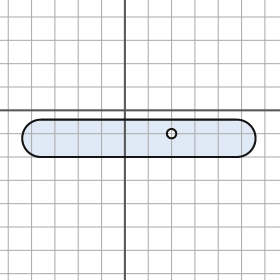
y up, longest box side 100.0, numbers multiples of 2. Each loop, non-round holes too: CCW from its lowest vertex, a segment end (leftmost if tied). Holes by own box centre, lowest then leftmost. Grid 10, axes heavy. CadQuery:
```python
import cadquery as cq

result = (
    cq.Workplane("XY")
    .moveTo(-36.0, -20.0)
    .lineTo(48.0, -20.0)
    .threePointArc((56.0, -12.0), (48.0, -4.0))
    .lineTo(-36.0, -4.0)
    .threePointArc((-44.0, -12.0), (-36.0, -20.0))
    .close()
    .moveTo(20.0, -10.0)
    .circle(2.0)
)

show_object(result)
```